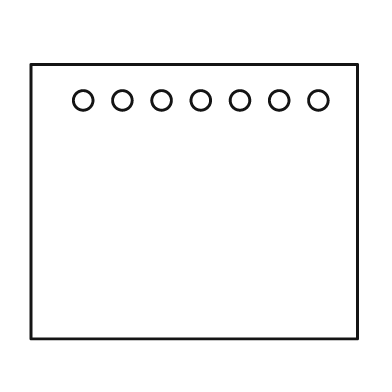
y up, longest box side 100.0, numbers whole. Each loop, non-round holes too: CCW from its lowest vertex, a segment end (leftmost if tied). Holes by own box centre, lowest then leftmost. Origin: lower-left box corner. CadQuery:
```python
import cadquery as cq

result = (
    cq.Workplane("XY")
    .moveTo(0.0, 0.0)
    .lineTo(100.0, 0.0)
    .lineTo(100.0, 84.0)
    .lineTo(0.0, 84.0)
    .close()
    .moveTo(16.0, 73.0)
    .circle(3.0)
    .moveTo(28.0, 73.0)
    .circle(3.0)
    .moveTo(40.0, 73.0)
    .circle(3.0)
    .moveTo(52.0, 73.0)
    .circle(3.0)
    .moveTo(64.0, 73.0)
    .circle(3.0)
    .moveTo(76.0, 73.0)
    .circle(3.0)
    .moveTo(88.0, 73.0)
    .circle(3.0)
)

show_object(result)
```